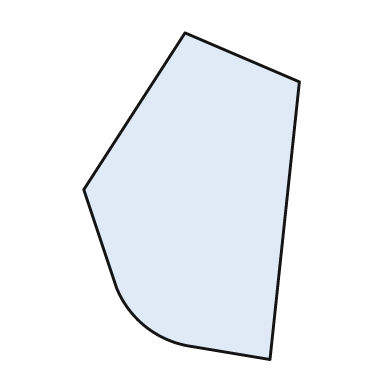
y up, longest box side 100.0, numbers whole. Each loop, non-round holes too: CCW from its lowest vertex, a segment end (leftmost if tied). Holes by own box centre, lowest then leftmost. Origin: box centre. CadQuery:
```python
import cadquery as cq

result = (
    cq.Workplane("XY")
    .moveTo(24.0, -50.0)
    .lineTo(33.0, 35.0)
    .lineTo(-2.0, 50.0)
    .lineTo(-33.0, 2.0)
    .lineTo(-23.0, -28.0)
    .threePointArc((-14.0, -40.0), (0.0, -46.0))
    .close()
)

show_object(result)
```